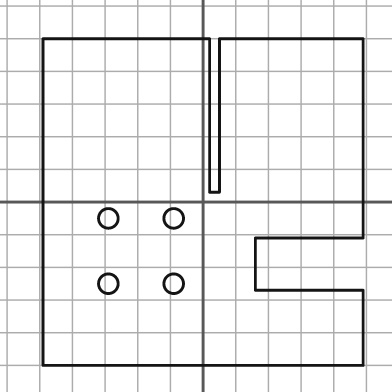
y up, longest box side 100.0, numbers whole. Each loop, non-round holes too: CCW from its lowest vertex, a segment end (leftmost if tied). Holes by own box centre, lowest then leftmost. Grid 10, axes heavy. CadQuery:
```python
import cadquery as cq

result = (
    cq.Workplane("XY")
    .moveTo(-49.0, -50.0)
    .lineTo(49.0, -50.0)
    .lineTo(49.0, -27.0)
    .lineTo(16.0, -27.0)
    .lineTo(16.0, -11.0)
    .lineTo(49.0, -11.0)
    .lineTo(49.0, 50.0)
    .lineTo(5.0, 50.0)
    .lineTo(5.0, 3.0)
    .lineTo(2.0, 3.0)
    .lineTo(2.0, 50.0)
    .lineTo(-49.0, 50.0)
    .close()
    .moveTo(-29.0, -25.0)
    .circle(3.0)
    .moveTo(-9.0, -25.0)
    .circle(3.0)
    .moveTo(-29.0, -5.0)
    .circle(3.0)
    .moveTo(-9.0, -5.0)
    .circle(3.0)
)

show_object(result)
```